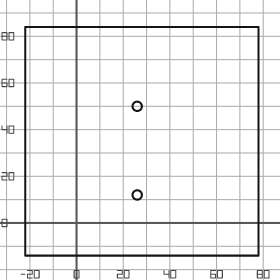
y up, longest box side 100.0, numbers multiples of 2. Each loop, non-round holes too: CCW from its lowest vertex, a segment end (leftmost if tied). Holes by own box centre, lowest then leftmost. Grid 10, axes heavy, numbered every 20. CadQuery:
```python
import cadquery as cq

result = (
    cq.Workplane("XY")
    .moveTo(-22.0, -14.0)
    .lineTo(78.0, -14.0)
    .lineTo(78.0, 84.0)
    .lineTo(-22.0, 84.0)
    .close()
    .moveTo(26.0, 12.0)
    .circle(2.0)
    .moveTo(26.0, 50.0)
    .circle(2.0)
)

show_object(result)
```